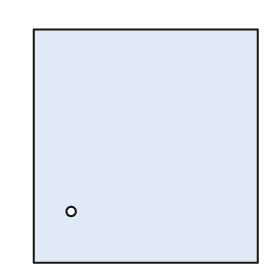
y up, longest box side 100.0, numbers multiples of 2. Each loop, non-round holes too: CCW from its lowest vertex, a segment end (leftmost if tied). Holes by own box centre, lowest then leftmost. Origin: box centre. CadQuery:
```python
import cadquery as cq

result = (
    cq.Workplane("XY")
    .moveTo(-48.0, -50.0)
    .lineTo(48.0, -50.0)
    .lineTo(48.0, 50.0)
    .lineTo(-48.0, 50.0)
    .close()
    .moveTo(-32.0, -28.0)
    .circle(2.0)
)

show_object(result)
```